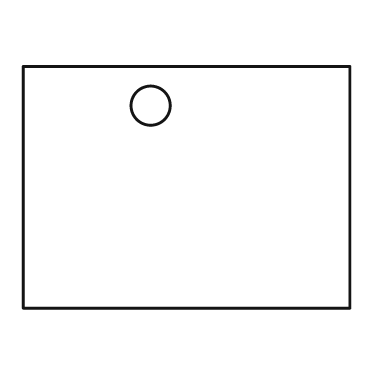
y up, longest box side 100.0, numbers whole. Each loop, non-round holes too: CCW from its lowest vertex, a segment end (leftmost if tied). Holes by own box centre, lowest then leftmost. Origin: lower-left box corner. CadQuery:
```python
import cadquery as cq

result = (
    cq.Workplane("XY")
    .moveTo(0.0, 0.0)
    .lineTo(100.0, 0.0)
    .lineTo(100.0, 74.0)
    .lineTo(0.0, 74.0)
    .close()
    .moveTo(39.0, 62.0)
    .circle(6.0)
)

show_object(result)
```